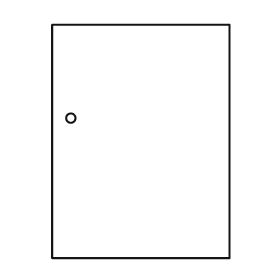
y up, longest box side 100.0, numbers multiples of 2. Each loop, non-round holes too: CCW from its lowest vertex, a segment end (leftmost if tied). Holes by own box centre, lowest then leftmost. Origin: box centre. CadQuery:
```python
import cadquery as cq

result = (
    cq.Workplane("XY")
    .moveTo(-38.0, -50.0)
    .lineTo(38.0, -50.0)
    .lineTo(38.0, 50.0)
    .lineTo(-38.0, 50.0)
    .close()
    .moveTo(-30.0, 10.0)
    .circle(2.0)
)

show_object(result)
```